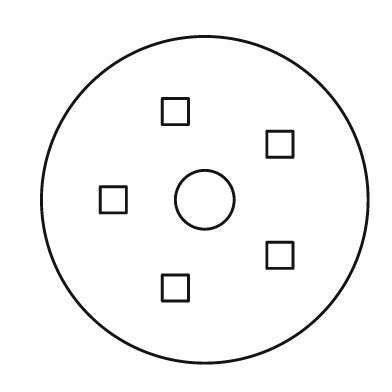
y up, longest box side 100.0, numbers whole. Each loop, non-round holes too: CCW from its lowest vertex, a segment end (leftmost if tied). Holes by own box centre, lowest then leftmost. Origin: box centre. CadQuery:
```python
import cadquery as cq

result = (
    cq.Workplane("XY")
    .moveTo(0.0, 0.0)
    .circle(50.0)
    .moveTo(-13.0, -31.0)
    .lineTo(-5.0, -31.0)
    .lineTo(-5.0, -23.0)
    .lineTo(-13.0, -23.0)
    .close()
    .moveTo(19.0, -21.0)
    .lineTo(27.0, -21.0)
    .lineTo(27.0, -13.0)
    .lineTo(19.0, -13.0)
    .close()
    .moveTo(-32.0, -4.0)
    .lineTo(-24.0, -4.0)
    .lineTo(-24.0, 4.0)
    .lineTo(-32.0, 4.0)
    .close()
    .moveTo(0.0, 0.0)
    .circle(9.0)
    .moveTo(19.0, 13.0)
    .lineTo(27.0, 13.0)
    .lineTo(27.0, 21.0)
    .lineTo(19.0, 21.0)
    .close()
    .moveTo(-13.0, 23.0)
    .lineTo(-5.0, 23.0)
    .lineTo(-5.0, 31.0)
    .lineTo(-13.0, 31.0)
    .close()
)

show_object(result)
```